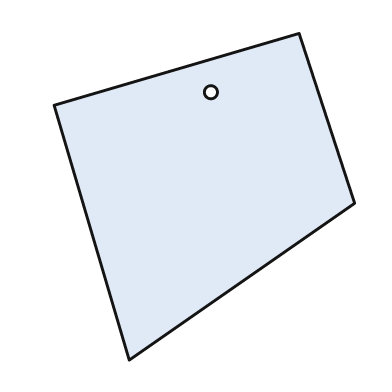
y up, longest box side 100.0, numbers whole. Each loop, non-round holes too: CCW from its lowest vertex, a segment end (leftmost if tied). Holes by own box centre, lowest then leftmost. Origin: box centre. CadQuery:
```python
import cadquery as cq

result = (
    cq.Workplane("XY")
    .moveTo(-23.0, -50.0)
    .lineTo(46.0, -2.0)
    .lineTo(29.0, 50.0)
    .lineTo(-46.0, 28.0)
    .close()
    .moveTo(2.0, 32.0)
    .circle(2.0)
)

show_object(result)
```